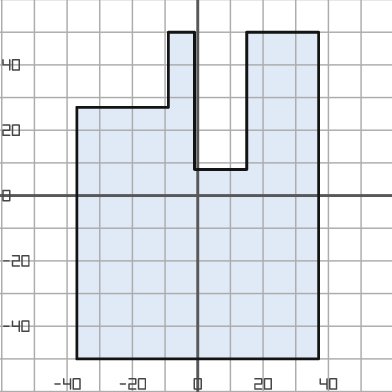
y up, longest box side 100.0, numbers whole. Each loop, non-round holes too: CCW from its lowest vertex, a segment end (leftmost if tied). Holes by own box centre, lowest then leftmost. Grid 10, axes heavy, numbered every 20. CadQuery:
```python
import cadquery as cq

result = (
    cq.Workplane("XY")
    .moveTo(-37.0, -50.0)
    .lineTo(37.0, -50.0)
    .lineTo(37.0, 50.0)
    .lineTo(15.0, 50.0)
    .lineTo(15.0, 8.0)
    .lineTo(-1.0, 8.0)
    .lineTo(-1.0, 50.0)
    .lineTo(-9.0, 50.0)
    .lineTo(-9.0, 27.0)
    .lineTo(-37.0, 27.0)
    .close()
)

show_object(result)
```